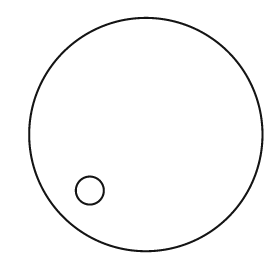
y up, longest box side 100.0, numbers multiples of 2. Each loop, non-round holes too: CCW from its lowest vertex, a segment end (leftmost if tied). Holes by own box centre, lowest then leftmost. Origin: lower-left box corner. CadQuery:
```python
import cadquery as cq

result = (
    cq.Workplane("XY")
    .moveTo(50.0, 50.0)
    .circle(50.0)
    .moveTo(26.0, 26.0)
    .circle(6.0)
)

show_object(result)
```